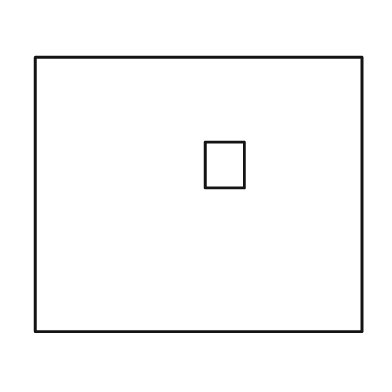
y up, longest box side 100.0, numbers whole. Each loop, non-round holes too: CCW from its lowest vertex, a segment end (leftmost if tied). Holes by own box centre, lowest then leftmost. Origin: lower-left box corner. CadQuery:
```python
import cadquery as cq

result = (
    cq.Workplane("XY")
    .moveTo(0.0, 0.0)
    .lineTo(100.0, 0.0)
    .lineTo(100.0, 84.0)
    .lineTo(0.0, 84.0)
    .close()
    .moveTo(52.0, 44.0)
    .lineTo(64.0, 44.0)
    .lineTo(64.0, 58.0)
    .lineTo(52.0, 58.0)
    .close()
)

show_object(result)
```